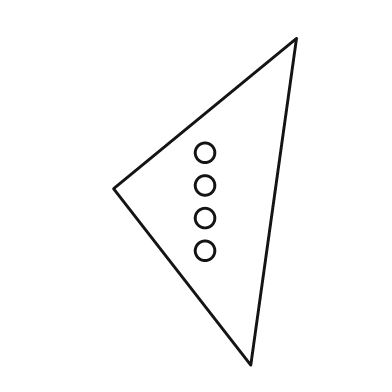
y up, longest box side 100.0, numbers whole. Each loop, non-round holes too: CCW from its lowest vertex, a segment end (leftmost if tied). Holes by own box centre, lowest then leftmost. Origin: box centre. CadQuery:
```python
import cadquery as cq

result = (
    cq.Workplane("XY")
    .moveTo(14.0, -50.0)
    .lineTo(28.0, 50.0)
    .lineTo(-28.0, 4.0)
    .close()
    .moveTo(0.0, -15.0)
    .circle(3.0)
    .moveTo(0.0, -5.0)
    .circle(3.0)
    .moveTo(0.0, 5.0)
    .circle(3.0)
    .moveTo(0.0, 15.0)
    .circle(3.0)
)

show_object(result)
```